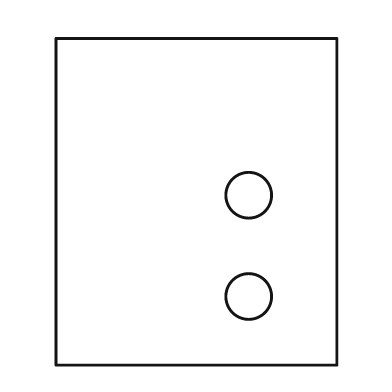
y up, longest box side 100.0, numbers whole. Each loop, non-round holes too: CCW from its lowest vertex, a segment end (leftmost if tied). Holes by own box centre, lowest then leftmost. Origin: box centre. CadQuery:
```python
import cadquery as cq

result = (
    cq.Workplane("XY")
    .moveTo(-43.0, -50.0)
    .lineTo(43.0, -50.0)
    .lineTo(43.0, 50.0)
    .lineTo(-43.0, 50.0)
    .close()
    .moveTo(16.0, -29.0)
    .circle(7.0)
    .moveTo(16.0, 2.0)
    .circle(7.0)
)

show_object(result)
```